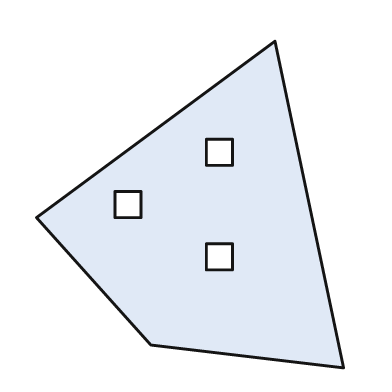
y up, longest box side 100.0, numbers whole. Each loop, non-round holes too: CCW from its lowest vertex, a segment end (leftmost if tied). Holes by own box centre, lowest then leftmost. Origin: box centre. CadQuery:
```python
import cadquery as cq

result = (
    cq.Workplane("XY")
    .moveTo(47.0, -50.0)
    .lineTo(26.0, 50.0)
    .lineTo(-47.0, -4.0)
    .lineTo(-12.0, -43.0)
    .close()
    .moveTo(5.0, -20.0)
    .lineTo(13.0, -20.0)
    .lineTo(13.0, -12.0)
    .lineTo(5.0, -12.0)
    .close()
    .moveTo(-23.0, -4.0)
    .lineTo(-15.0, -4.0)
    .lineTo(-15.0, 4.0)
    .lineTo(-23.0, 4.0)
    .close()
    .moveTo(5.0, 12.0)
    .lineTo(13.0, 12.0)
    .lineTo(13.0, 20.0)
    .lineTo(5.0, 20.0)
    .close()
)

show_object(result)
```